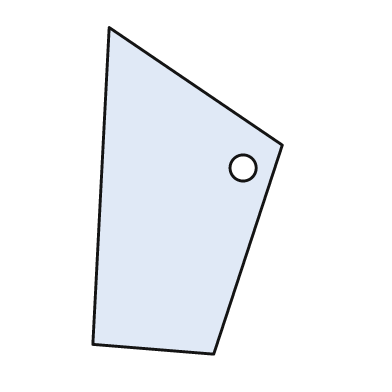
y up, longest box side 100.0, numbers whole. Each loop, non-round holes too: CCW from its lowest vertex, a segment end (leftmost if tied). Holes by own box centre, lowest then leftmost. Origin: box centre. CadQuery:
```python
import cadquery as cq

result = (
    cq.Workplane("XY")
    .moveTo(8.0, -50.0)
    .lineTo(29.0, 14.0)
    .lineTo(-24.0, 50.0)
    .lineTo(-29.0, -47.0)
    .close()
    .moveTo(17.0, 7.0)
    .circle(4.0)
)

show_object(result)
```